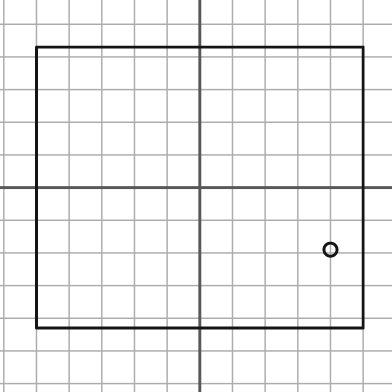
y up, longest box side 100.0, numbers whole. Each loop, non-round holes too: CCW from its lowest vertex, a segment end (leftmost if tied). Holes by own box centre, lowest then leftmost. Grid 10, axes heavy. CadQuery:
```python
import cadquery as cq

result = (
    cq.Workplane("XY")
    .moveTo(-50.0, -43.0)
    .lineTo(50.0, -43.0)
    .lineTo(50.0, 43.0)
    .lineTo(-50.0, 43.0)
    .close()
    .moveTo(40.0, -19.0)
    .circle(2.0)
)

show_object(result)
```